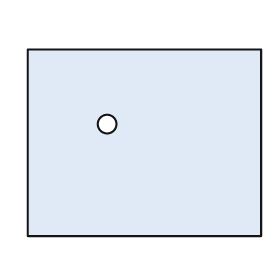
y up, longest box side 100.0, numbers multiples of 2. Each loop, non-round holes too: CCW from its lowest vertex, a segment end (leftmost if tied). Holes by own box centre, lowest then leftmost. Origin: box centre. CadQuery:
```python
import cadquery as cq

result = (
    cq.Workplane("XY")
    .moveTo(-50.0, -40.0)
    .lineTo(50.0, -40.0)
    .lineTo(50.0, 40.0)
    .lineTo(-50.0, 40.0)
    .close()
    .moveTo(-16.0, 8.0)
    .circle(4.0)
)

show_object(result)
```